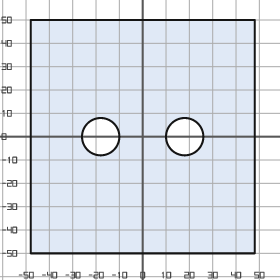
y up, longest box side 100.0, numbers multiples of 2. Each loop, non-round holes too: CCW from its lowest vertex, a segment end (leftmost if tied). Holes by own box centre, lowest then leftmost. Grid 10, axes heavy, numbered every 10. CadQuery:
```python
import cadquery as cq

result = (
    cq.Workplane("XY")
    .moveTo(-48.0, -50.0)
    .lineTo(48.0, -50.0)
    .lineTo(48.0, 50.0)
    .lineTo(-48.0, 50.0)
    .close()
    .moveTo(-18.0, 0.0)
    .circle(8.0)
    .moveTo(18.0, 0.0)
    .circle(8.0)
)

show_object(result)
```